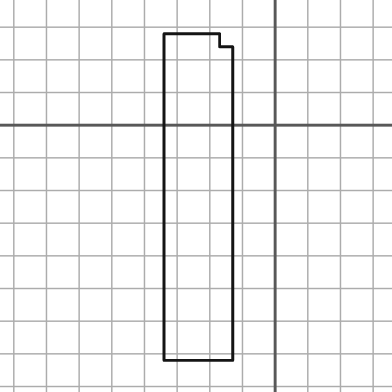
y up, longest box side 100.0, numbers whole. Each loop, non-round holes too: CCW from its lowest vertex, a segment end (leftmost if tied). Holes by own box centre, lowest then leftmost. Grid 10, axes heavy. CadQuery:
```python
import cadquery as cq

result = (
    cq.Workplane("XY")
    .moveTo(-34.0, -72.0)
    .lineTo(-13.0, -72.0)
    .lineTo(-13.0, 24.0)
    .lineTo(-17.0, 24.0)
    .lineTo(-17.0, 28.0)
    .lineTo(-34.0, 28.0)
    .close()
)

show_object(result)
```